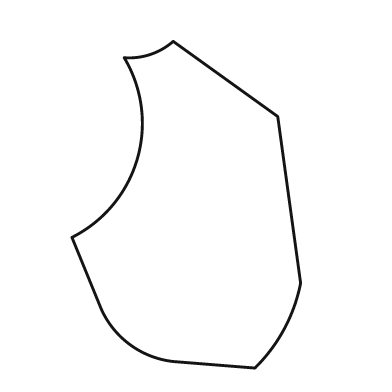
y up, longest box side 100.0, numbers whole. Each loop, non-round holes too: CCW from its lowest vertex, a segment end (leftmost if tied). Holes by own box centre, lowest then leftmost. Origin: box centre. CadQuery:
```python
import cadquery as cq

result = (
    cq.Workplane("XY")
    .moveTo(21.0, -50.0)
    .threePointArc((30.0, -38.0), (35.0, -24.0))
    .lineTo(28.0, 27.0)
    .lineTo(-4.0, 50.0)
    .threePointArc((-11.0, 46.0), (-19.0, 45.0))
    .threePointArc((-15.0, 14.0), (-35.0, -10.0))
    .lineTo(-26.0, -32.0)
    .threePointArc((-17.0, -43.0), (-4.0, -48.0))
    .close()
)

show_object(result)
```